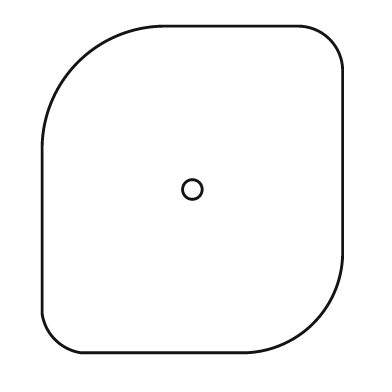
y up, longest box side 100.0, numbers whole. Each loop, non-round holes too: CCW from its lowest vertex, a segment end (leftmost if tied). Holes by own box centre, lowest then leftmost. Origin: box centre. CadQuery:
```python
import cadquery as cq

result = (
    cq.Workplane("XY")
    .moveTo(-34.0, -50.0)
    .lineTo(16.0, -50.0)
    .threePointArc((37.0, -41.0), (46.0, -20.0))
    .lineTo(46.0, 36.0)
    .threePointArc((42.0, 46.0), (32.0, 50.0))
    .lineTo(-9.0, 50.0)
    .threePointArc((-35.0, 39.0), (-46.0, 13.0))
    .lineTo(-46.0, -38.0)
    .threePointArc((-42.0, -46.0), (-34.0, -50.0))
    .close()
    .moveTo(0.0, 0.0)
    .circle(3.0)
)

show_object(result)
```